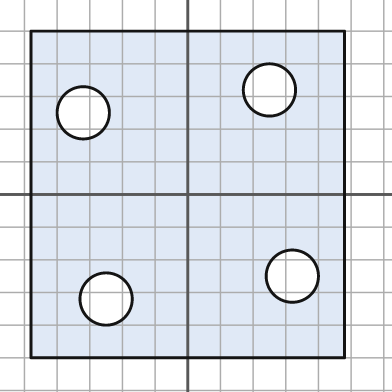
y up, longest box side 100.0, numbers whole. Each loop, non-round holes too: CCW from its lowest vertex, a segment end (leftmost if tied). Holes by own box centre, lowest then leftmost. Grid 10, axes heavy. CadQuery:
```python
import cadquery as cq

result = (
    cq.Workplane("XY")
    .moveTo(-48.0, -50.0)
    .lineTo(48.0, -50.0)
    .lineTo(48.0, 50.0)
    .lineTo(-48.0, 50.0)
    .close()
    .moveTo(-25.0, -32.0)
    .circle(8.0)
    .moveTo(32.0, -25.0)
    .circle(8.0)
    .moveTo(-32.0, 25.0)
    .circle(8.0)
    .moveTo(25.0, 32.0)
    .circle(8.0)
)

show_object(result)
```